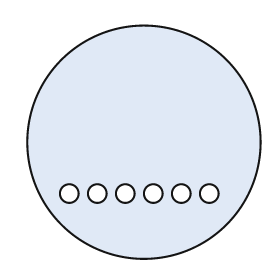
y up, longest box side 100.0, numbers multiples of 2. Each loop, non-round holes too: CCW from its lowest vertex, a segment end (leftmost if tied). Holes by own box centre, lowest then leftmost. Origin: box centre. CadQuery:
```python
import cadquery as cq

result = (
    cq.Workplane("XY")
    .moveTo(0.0, 0.0)
    .circle(50.0)
    .moveTo(-32.0, -22.0)
    .circle(4.0)
    .moveTo(-20.0, -22.0)
    .circle(4.0)
    .moveTo(-8.0, -22.0)
    .circle(4.0)
    .moveTo(4.0, -22.0)
    .circle(4.0)
    .moveTo(16.0, -22.0)
    .circle(4.0)
    .moveTo(28.0, -22.0)
    .circle(4.0)
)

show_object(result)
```